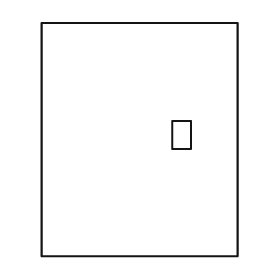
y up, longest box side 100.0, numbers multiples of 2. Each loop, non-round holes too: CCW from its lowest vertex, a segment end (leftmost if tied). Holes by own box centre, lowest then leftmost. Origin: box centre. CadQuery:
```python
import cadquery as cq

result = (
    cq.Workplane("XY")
    .moveTo(-42.0, -50.0)
    .lineTo(42.0, -50.0)
    .lineTo(42.0, 50.0)
    .lineTo(-42.0, 50.0)
    .close()
    .moveTo(14.0, -4.0)
    .lineTo(22.0, -4.0)
    .lineTo(22.0, 8.0)
    .lineTo(14.0, 8.0)
    .close()
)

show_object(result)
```